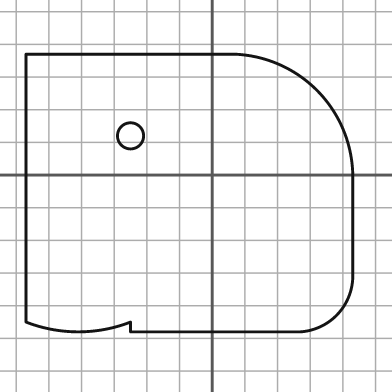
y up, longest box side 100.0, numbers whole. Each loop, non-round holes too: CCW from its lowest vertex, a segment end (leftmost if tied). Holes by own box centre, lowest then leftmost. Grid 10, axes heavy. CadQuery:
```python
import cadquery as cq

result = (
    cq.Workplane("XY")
    .moveTo(-25.0, -48.0)
    .lineTo(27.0, -48.0)
    .threePointArc((38.0, -43.0), (43.0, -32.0))
    .lineTo(43.0, 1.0)
    .threePointArc((32.0, 26.0), (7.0, 37.0))
    .lineTo(-57.0, 37.0)
    .lineTo(-57.0, -45.0)
    .threePointArc((-41.0, -48.0), (-25.0, -45.0))
    .close()
    .moveTo(-25.0, 12.0)
    .circle(4.0)
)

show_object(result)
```